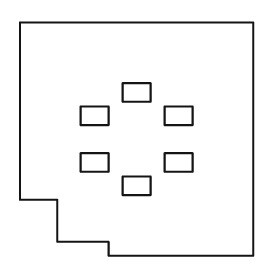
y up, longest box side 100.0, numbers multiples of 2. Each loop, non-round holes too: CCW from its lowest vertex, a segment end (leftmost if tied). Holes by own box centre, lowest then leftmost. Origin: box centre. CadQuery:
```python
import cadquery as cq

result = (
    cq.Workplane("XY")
    .moveTo(-12.0, -50.0)
    .lineTo(50.0, -50.0)
    .lineTo(50.0, 50.0)
    .lineTo(-50.0, 50.0)
    .lineTo(-50.0, -26.0)
    .lineTo(-34.0, -26.0)
    .lineTo(-34.0, -44.0)
    .lineTo(-12.0, -44.0)
    .close()
    .moveTo(-6.0, -24.0)
    .lineTo(6.0, -24.0)
    .lineTo(6.0, -16.0)
    .lineTo(-6.0, -16.0)
    .close()
    .moveTo(-24.0, -14.0)
    .lineTo(-12.0, -14.0)
    .lineTo(-12.0, -6.0)
    .lineTo(-24.0, -6.0)
    .close()
    .moveTo(12.0, -14.0)
    .lineTo(24.0, -14.0)
    .lineTo(24.0, -6.0)
    .lineTo(12.0, -6.0)
    .close()
    .moveTo(-24.0, 6.0)
    .lineTo(-12.0, 6.0)
    .lineTo(-12.0, 14.0)
    .lineTo(-24.0, 14.0)
    .close()
    .moveTo(12.0, 6.0)
    .lineTo(24.0, 6.0)
    .lineTo(24.0, 14.0)
    .lineTo(12.0, 14.0)
    .close()
    .moveTo(-6.0, 16.0)
    .lineTo(6.0, 16.0)
    .lineTo(6.0, 24.0)
    .lineTo(-6.0, 24.0)
    .close()
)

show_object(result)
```